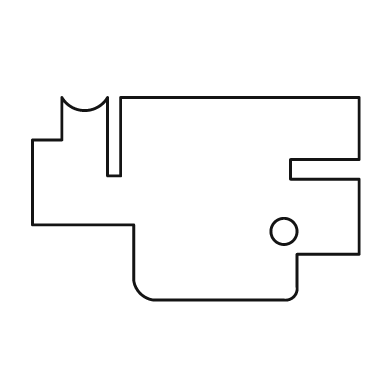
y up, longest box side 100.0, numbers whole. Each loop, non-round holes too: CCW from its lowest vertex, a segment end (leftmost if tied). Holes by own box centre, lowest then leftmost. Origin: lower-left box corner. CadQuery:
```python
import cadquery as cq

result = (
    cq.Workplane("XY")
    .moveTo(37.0, 0.0)
    .lineTo(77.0, 0.0)
    .threePointArc((80.0, 1.0), (81.0, 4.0))
    .lineTo(81.0, 14.0)
    .lineTo(100.0, 14.0)
    .lineTo(100.0, 37.0)
    .lineTo(79.0, 37.0)
    .lineTo(79.0, 43.0)
    .lineTo(100.0, 43.0)
    .lineTo(100.0, 62.0)
    .lineTo(27.0, 62.0)
    .lineTo(27.0, 38.0)
    .lineTo(23.0, 38.0)
    .lineTo(23.0, 62.0)
    .threePointArc((16.0, 58.0), (9.0, 62.0))
    .lineTo(9.0, 49.0)
    .lineTo(0.0, 49.0)
    .lineTo(0.0, 23.0)
    .lineTo(31.0, 23.0)
    .lineTo(31.0, 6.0)
    .threePointArc((33.0, 2.0), (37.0, 0.0))
    .close()
    .moveTo(77.0, 21.0)
    .circle(4.0)
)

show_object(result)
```